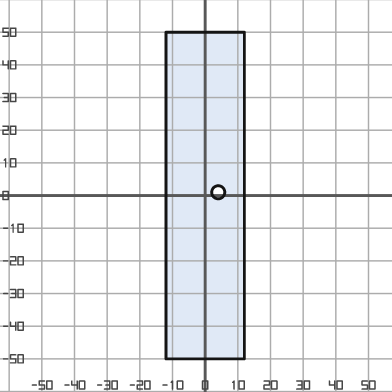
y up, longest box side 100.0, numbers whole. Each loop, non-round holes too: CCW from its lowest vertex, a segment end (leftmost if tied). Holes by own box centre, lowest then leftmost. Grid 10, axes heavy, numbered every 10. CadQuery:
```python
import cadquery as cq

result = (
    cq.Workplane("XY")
    .moveTo(-12.0, -50.0)
    .lineTo(12.0, -50.0)
    .lineTo(12.0, 50.0)
    .lineTo(-12.0, 50.0)
    .close()
    .moveTo(4.0, 1.0)
    .circle(2.0)
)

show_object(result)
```